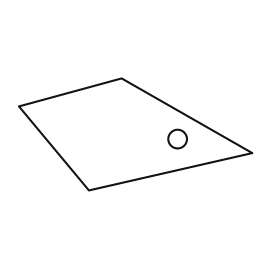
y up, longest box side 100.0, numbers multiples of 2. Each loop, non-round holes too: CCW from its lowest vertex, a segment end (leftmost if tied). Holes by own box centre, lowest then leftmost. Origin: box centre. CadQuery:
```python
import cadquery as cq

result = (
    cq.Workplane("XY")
    .moveTo(-20.0, -24.0)
    .lineTo(50.0, -8.0)
    .lineTo(-6.0, 24.0)
    .lineTo(-50.0, 12.0)
    .close()
    .moveTo(18.0, -2.0)
    .circle(4.0)
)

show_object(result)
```